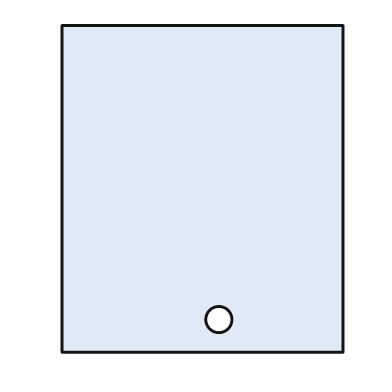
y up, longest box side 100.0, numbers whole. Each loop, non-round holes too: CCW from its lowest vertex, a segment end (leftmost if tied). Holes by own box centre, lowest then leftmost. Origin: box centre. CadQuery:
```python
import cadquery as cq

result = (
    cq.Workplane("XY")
    .moveTo(-43.0, -50.0)
    .lineTo(43.0, -50.0)
    .lineTo(43.0, 50.0)
    .lineTo(-43.0, 50.0)
    .close()
    .moveTo(5.0, -40.0)
    .circle(4.0)
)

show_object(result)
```